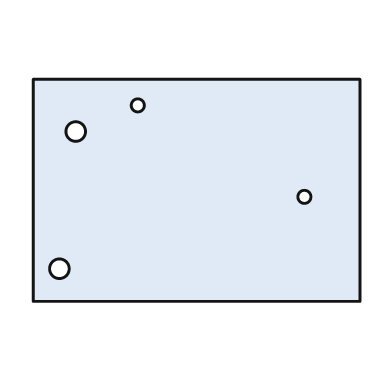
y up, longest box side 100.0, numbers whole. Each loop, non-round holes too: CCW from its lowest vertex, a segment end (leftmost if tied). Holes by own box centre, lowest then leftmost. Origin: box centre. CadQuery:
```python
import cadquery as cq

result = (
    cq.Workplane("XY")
    .moveTo(-50.0, -34.0)
    .lineTo(50.0, -34.0)
    .lineTo(50.0, 34.0)
    .lineTo(-50.0, 34.0)
    .close()
    .moveTo(-42.0, -24.0)
    .circle(3.0)
    .moveTo(33.0, -2.0)
    .circle(2.0)
    .moveTo(-37.0, 18.0)
    .circle(3.0)
    .moveTo(-18.0, 26.0)
    .circle(2.0)
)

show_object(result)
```